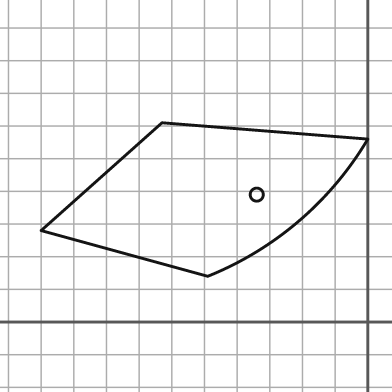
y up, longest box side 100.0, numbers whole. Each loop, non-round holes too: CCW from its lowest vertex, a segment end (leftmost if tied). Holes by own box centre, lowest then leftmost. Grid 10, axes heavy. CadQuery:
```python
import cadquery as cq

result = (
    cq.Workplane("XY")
    .moveTo(-49.0, 14.0)
    .threePointArc((-21.0, 31.0), (0.0, 56.0))
    .lineTo(-63.0, 61.0)
    .lineTo(-100.0, 28.0)
    .close()
    .moveTo(-34.0, 39.0)
    .circle(2.0)
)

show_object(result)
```